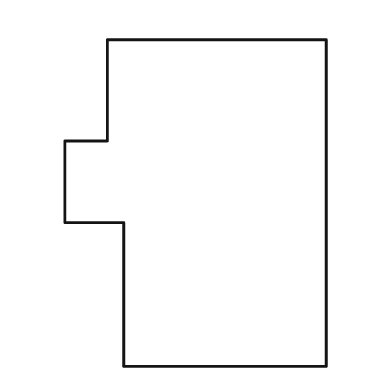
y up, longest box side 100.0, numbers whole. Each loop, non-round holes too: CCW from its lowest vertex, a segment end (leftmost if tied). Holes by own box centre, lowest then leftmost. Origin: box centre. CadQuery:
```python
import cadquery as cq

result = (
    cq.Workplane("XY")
    .moveTo(-22.0, -50.0)
    .lineTo(40.0, -50.0)
    .lineTo(40.0, 50.0)
    .lineTo(-27.0, 50.0)
    .lineTo(-27.0, 19.0)
    .lineTo(-40.0, 19.0)
    .lineTo(-40.0, -6.0)
    .lineTo(-22.0, -6.0)
    .close()
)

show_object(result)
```